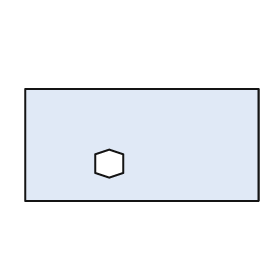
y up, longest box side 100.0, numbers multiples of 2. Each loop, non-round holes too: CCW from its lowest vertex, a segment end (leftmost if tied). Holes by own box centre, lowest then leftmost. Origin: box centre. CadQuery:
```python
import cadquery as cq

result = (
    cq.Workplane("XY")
    .moveTo(-50.0, -24.0)
    .lineTo(50.0, -24.0)
    .lineTo(50.0, 24.0)
    .lineTo(-50.0, 24.0)
    .close()
    .moveTo(-14.0, -14.0)
    .lineTo(-8.0, -12.0)
    .lineTo(-8.0, -4.0)
    .lineTo(-14.0, -2.0)
    .lineTo(-20.0, -4.0)
    .lineTo(-20.0, -12.0)
    .close()
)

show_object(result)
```